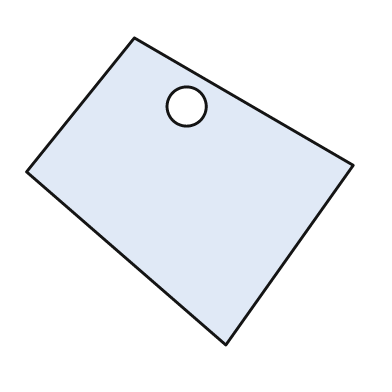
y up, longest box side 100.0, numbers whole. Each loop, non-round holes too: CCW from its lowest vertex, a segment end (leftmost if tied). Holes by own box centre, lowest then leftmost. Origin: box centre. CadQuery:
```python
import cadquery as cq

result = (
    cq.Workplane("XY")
    .moveTo(11.0, -47.0)
    .lineTo(50.0, 8.0)
    .lineTo(-17.0, 47.0)
    .lineTo(-50.0, 6.0)
    .close()
    .moveTo(-1.0, 26.0)
    .circle(6.0)
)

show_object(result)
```